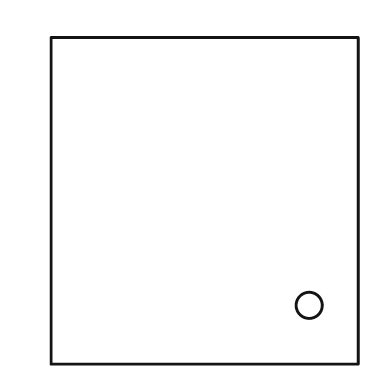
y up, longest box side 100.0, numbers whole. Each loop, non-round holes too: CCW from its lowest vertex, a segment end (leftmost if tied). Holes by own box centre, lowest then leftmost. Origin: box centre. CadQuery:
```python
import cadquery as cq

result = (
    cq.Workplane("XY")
    .moveTo(-47.0, -50.0)
    .lineTo(47.0, -50.0)
    .lineTo(47.0, 50.0)
    .lineTo(-47.0, 50.0)
    .close()
    .moveTo(32.0, -32.0)
    .circle(4.0)
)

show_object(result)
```